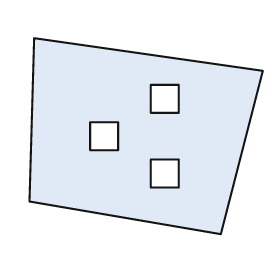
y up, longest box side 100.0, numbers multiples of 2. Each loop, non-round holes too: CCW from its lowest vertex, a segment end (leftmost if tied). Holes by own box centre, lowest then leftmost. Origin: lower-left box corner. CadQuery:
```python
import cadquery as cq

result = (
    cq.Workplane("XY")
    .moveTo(82.0, 0.0)
    .lineTo(100.0, 70.0)
    .lineTo(2.0, 84.0)
    .lineTo(0.0, 14.0)
    .close()
    .moveTo(52.0, 20.0)
    .lineTo(64.0, 20.0)
    .lineTo(64.0, 32.0)
    .lineTo(52.0, 32.0)
    .close()
    .moveTo(26.0, 36.0)
    .lineTo(38.0, 36.0)
    .lineTo(38.0, 48.0)
    .lineTo(26.0, 48.0)
    .close()
    .moveTo(52.0, 52.0)
    .lineTo(64.0, 52.0)
    .lineTo(64.0, 64.0)
    .lineTo(52.0, 64.0)
    .close()
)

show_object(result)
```